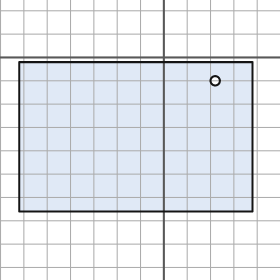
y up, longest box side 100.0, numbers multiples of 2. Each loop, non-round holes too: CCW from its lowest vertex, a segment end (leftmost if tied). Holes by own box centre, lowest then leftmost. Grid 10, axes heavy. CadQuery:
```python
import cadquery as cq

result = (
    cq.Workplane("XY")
    .moveTo(-62.0, -66.0)
    .lineTo(38.0, -66.0)
    .lineTo(38.0, -2.0)
    .lineTo(-62.0, -2.0)
    .close()
    .moveTo(22.0, -10.0)
    .circle(2.0)
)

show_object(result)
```